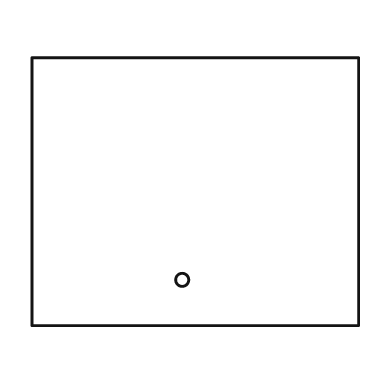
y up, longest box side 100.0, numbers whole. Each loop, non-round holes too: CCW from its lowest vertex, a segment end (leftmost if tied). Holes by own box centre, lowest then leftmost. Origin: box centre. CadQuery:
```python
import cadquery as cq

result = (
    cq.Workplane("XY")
    .moveTo(-50.0, -41.0)
    .lineTo(50.0, -41.0)
    .lineTo(50.0, 41.0)
    .lineTo(-50.0, 41.0)
    .close()
    .moveTo(-4.0, -27.0)
    .circle(2.0)
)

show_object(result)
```